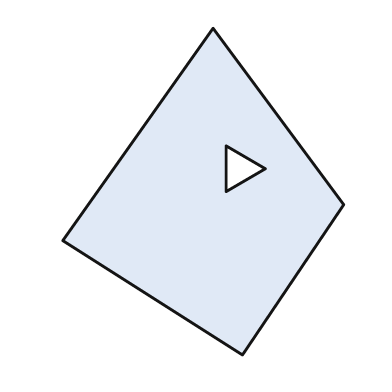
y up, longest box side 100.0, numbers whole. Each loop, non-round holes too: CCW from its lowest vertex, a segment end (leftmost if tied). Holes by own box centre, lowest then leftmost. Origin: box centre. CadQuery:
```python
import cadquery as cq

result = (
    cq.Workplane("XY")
    .moveTo(12.0, -50.0)
    .lineTo(43.0, -4.0)
    .lineTo(3.0, 50.0)
    .lineTo(-43.0, -15.0)
    .close()
    .moveTo(7.0, 0.0)
    .lineTo(19.0, 7.0)
    .lineTo(7.0, 14.0)
    .close()
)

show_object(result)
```